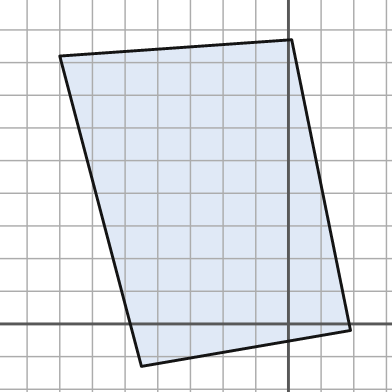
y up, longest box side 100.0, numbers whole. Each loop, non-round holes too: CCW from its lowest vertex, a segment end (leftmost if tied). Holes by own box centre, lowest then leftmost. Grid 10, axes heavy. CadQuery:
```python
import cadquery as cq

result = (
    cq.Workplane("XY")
    .moveTo(-45.0, -13.0)
    .lineTo(19.0, -2.0)
    .lineTo(1.0, 87.0)
    .lineTo(-70.0, 82.0)
    .close()
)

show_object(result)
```